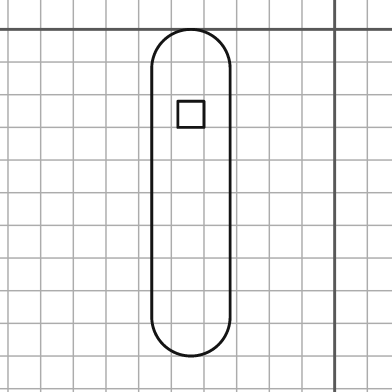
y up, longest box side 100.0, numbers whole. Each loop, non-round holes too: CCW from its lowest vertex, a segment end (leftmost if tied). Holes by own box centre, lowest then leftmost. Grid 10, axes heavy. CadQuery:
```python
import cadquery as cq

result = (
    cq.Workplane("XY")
    .moveTo(-56.0, -88.0)
    .threePointArc((-44.0, -100.0), (-32.0, -88.0))
    .lineTo(-32.0, -12.0)
    .threePointArc((-44.0, 0.0), (-56.0, -12.0))
    .close()
    .moveTo(-48.0, -30.0)
    .lineTo(-40.0, -30.0)
    .lineTo(-40.0, -22.0)
    .lineTo(-48.0, -22.0)
    .close()
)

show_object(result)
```